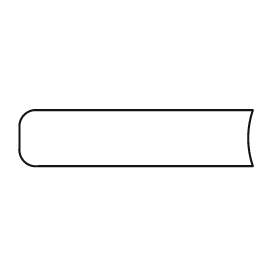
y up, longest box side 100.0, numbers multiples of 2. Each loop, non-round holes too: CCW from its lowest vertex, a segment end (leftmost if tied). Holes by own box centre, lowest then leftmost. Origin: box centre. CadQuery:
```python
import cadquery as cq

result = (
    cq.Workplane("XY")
    .moveTo(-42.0, -12.0)
    .lineTo(50.0, -12.0)
    .threePointArc((48.0, 0.0), (50.0, 12.0))
    .lineTo(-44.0, 12.0)
    .threePointArc((-48.0, 10.0), (-50.0, 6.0))
    .lineTo(-50.0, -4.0)
    .threePointArc((-48.0, -10.0), (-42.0, -12.0))
    .close()
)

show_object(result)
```